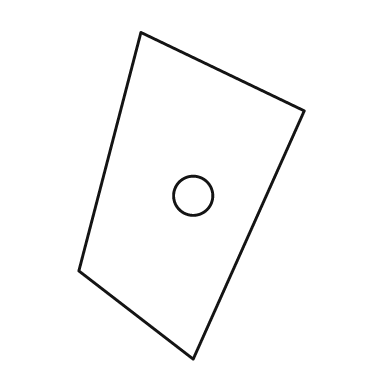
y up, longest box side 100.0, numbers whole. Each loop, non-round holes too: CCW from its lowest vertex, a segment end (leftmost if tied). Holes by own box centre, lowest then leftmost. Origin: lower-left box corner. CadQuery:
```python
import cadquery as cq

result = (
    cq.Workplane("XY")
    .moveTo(35.0, 0.0)
    .lineTo(69.0, 76.0)
    .lineTo(19.0, 100.0)
    .lineTo(0.0, 27.0)
    .close()
    .moveTo(35.0, 50.0)
    .circle(6.0)
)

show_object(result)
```